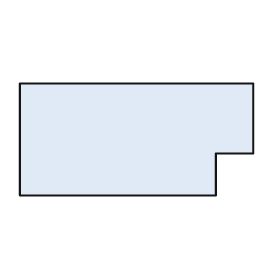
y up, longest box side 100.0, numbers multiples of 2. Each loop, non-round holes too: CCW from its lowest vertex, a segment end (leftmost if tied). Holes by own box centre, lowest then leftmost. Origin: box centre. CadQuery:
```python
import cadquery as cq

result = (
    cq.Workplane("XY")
    .moveTo(-50.0, -24.0)
    .lineTo(34.0, -24.0)
    .lineTo(34.0, -6.0)
    .lineTo(50.0, -6.0)
    .lineTo(50.0, 24.0)
    .lineTo(-50.0, 24.0)
    .close()
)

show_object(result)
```